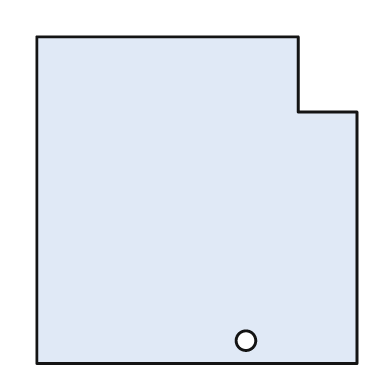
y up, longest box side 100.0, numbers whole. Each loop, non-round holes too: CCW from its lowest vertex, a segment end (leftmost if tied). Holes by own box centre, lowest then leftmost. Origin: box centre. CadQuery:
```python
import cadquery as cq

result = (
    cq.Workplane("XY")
    .moveTo(-49.0, -50.0)
    .lineTo(49.0, -50.0)
    .lineTo(49.0, 27.0)
    .lineTo(31.0, 27.0)
    .lineTo(31.0, 50.0)
    .lineTo(-49.0, 50.0)
    .close()
    .moveTo(15.0, -43.0)
    .circle(3.0)
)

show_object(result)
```